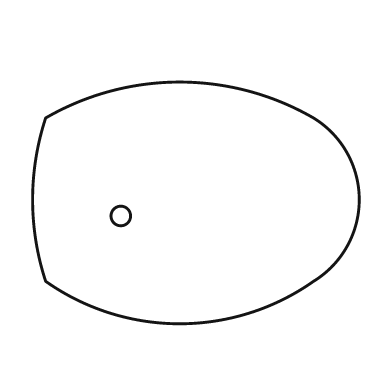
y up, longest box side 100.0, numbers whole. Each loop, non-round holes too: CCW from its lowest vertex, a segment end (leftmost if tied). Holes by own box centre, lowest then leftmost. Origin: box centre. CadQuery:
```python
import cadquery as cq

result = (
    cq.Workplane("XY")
    .moveTo(-46.0, -24.0)
    .threePointArc((-5.0, -37.0), (36.0, -24.0))
    .threePointArc((50.0, 1.0), (36.0, 26.0))
    .threePointArc((-5.0, 37.0), (-46.0, 26.0))
    .threePointArc((-50.0, 1.0), (-46.0, -24.0))
    .close()
    .moveTo(-23.0, -4.0)
    .circle(3.0)
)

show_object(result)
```